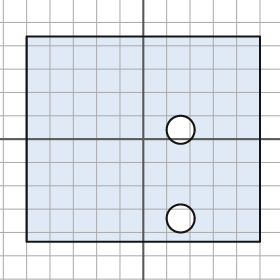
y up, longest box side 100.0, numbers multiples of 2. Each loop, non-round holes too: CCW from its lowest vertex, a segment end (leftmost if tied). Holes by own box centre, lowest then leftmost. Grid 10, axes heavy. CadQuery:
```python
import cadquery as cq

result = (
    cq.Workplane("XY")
    .moveTo(-50.0, -44.0)
    .lineTo(50.0, -44.0)
    .lineTo(50.0, 44.0)
    .lineTo(-50.0, 44.0)
    .close()
    .moveTo(16.0, -34.0)
    .circle(6.0)
    .moveTo(16.0, 4.0)
    .circle(6.0)
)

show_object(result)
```